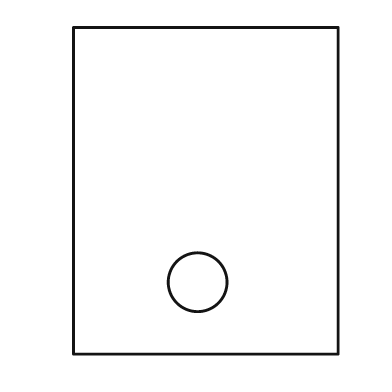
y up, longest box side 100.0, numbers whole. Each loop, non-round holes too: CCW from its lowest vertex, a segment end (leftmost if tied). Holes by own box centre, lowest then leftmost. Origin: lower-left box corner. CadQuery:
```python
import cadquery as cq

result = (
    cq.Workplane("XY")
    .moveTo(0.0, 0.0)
    .lineTo(81.0, 0.0)
    .lineTo(81.0, 100.0)
    .lineTo(0.0, 100.0)
    .close()
    .moveTo(38.0, 22.0)
    .circle(9.0)
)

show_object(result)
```